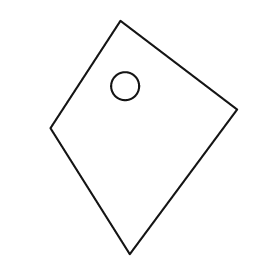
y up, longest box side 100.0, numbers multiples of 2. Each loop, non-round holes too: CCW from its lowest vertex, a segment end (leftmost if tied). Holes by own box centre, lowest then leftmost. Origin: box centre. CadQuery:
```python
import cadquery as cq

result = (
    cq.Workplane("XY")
    .moveTo(-6.0, -50.0)
    .lineTo(40.0, 12.0)
    .lineTo(-10.0, 50.0)
    .lineTo(-40.0, 4.0)
    .close()
    .moveTo(-8.0, 22.0)
    .circle(6.0)
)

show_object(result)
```